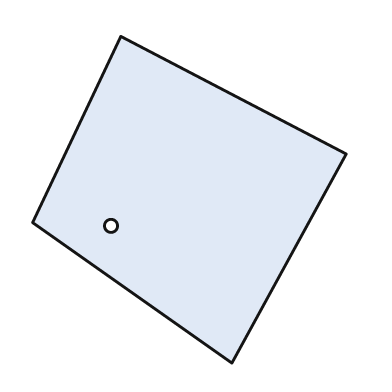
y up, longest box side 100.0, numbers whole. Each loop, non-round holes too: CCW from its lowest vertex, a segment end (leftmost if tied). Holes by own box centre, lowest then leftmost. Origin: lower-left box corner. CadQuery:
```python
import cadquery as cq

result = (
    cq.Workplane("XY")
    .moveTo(61.0, 0.0)
    .lineTo(96.0, 64.0)
    .lineTo(27.0, 100.0)
    .lineTo(0.0, 43.0)
    .close()
    .moveTo(24.0, 42.0)
    .circle(2.0)
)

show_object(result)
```